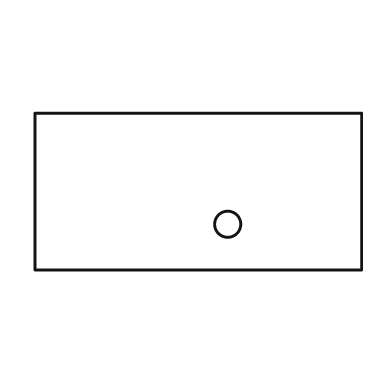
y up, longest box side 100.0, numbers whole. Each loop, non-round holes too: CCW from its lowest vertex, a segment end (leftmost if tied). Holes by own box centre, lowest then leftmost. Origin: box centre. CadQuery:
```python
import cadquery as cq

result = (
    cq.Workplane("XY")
    .moveTo(-50.0, -24.0)
    .lineTo(50.0, -24.0)
    .lineTo(50.0, 24.0)
    .lineTo(-50.0, 24.0)
    .close()
    .moveTo(9.0, -10.0)
    .circle(4.0)
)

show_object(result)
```